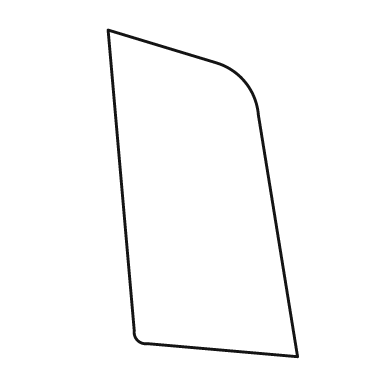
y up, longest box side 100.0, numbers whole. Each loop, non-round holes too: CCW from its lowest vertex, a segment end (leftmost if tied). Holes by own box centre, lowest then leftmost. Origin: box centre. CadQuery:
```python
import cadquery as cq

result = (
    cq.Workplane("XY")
    .moveTo(29.0, -50.0)
    .lineTo(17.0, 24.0)
    .threePointArc((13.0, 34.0), (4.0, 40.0))
    .lineTo(-29.0, 50.0)
    .lineTo(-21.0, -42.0)
    .threePointArc((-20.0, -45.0), (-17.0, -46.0))
    .close()
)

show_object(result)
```